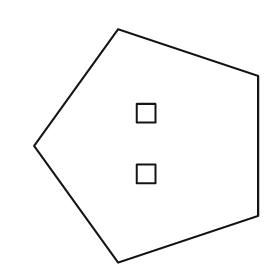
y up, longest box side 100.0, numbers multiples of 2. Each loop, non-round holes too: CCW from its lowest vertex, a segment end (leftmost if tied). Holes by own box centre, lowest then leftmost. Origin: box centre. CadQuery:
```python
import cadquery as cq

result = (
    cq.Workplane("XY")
    .moveTo(-12.0, -50.0)
    .lineTo(48.0, -30.0)
    .lineTo(48.0, 30.0)
    .lineTo(-12.0, 50.0)
    .lineTo(-48.0, 0.0)
    .close()
    .moveTo(-4.0, -16.0)
    .lineTo(4.0, -16.0)
    .lineTo(4.0, -8.0)
    .lineTo(-4.0, -8.0)
    .close()
    .moveTo(-4.0, 10.0)
    .lineTo(4.0, 10.0)
    .lineTo(4.0, 18.0)
    .lineTo(-4.0, 18.0)
    .close()
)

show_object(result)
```